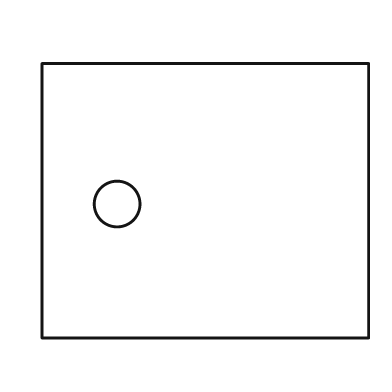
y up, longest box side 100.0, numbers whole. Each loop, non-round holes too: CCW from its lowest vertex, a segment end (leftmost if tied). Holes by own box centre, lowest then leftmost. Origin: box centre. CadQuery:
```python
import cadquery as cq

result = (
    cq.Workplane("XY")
    .moveTo(-50.0, -42.0)
    .lineTo(50.0, -42.0)
    .lineTo(50.0, 42.0)
    .lineTo(-50.0, 42.0)
    .close()
    .moveTo(-27.0, -1.0)
    .circle(7.0)
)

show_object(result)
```